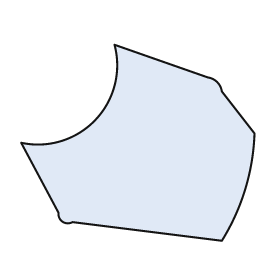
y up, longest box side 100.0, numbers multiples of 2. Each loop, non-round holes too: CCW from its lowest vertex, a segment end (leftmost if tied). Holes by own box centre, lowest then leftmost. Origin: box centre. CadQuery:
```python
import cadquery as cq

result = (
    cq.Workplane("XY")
    .moveTo(36.0, -42.0)
    .threePointArc((46.0, -20.0), (50.0, 4.0))
    .lineTo(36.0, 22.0)
    .threePointArc((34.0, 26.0), (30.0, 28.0))
    .lineTo(-10.0, 42.0)
    .threePointArc((-18.0, 10.0), (-50.0, 0.0))
    .lineTo(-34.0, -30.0)
    .threePointArc((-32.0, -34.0), (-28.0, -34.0))
    .close()
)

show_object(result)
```